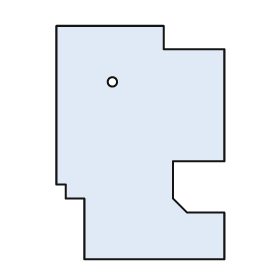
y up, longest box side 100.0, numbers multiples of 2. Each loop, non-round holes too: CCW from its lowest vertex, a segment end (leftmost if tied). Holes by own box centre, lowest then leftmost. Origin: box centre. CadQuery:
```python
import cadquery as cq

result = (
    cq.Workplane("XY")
    .moveTo(-24.0, -50.0)
    .lineTo(36.0, -50.0)
    .lineTo(36.0, -30.0)
    .lineTo(20.0, -30.0)
    .lineTo(14.0, -24.0)
    .lineTo(14.0, -8.0)
    .lineTo(36.0, -8.0)
    .lineTo(36.0, 40.0)
    .lineTo(10.0, 40.0)
    .lineTo(10.0, 50.0)
    .lineTo(-36.0, 50.0)
    .lineTo(-36.0, -18.0)
    .lineTo(-32.0, -18.0)
    .lineTo(-32.0, -24.0)
    .lineTo(-24.0, -24.0)
    .close()
    .moveTo(-12.0, 26.0)
    .circle(2.0)
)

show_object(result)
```